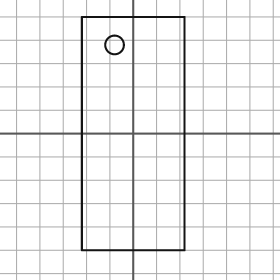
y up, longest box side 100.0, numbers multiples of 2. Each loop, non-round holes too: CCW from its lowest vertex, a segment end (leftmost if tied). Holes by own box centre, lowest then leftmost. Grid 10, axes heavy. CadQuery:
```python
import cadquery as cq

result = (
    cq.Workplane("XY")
    .moveTo(-22.0, -50.0)
    .lineTo(22.0, -50.0)
    .lineTo(22.0, 50.0)
    .lineTo(-22.0, 50.0)
    .close()
    .moveTo(-8.0, 38.0)
    .circle(4.0)
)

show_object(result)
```